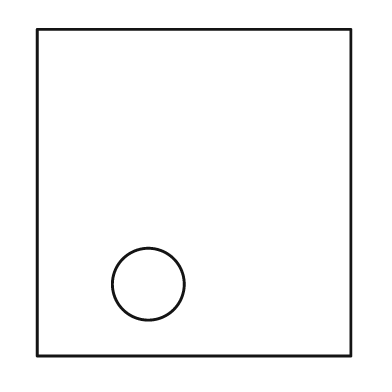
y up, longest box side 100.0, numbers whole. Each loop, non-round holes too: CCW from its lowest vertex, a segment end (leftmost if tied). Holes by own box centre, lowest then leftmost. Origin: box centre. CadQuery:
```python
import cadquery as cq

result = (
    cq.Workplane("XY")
    .moveTo(-48.0, -50.0)
    .lineTo(48.0, -50.0)
    .lineTo(48.0, 50.0)
    .lineTo(-48.0, 50.0)
    .close()
    .moveTo(-14.0, -28.0)
    .circle(11.0)
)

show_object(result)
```